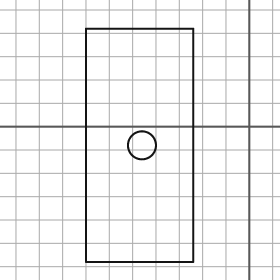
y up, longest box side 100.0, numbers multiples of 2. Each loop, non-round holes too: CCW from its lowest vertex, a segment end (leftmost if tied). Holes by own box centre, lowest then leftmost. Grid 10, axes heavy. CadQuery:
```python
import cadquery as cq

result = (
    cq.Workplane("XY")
    .moveTo(-70.0, -58.0)
    .lineTo(-24.0, -58.0)
    .lineTo(-24.0, 42.0)
    .lineTo(-70.0, 42.0)
    .close()
    .moveTo(-46.0, -8.0)
    .circle(6.0)
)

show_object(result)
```